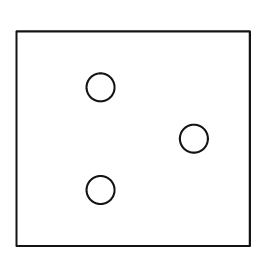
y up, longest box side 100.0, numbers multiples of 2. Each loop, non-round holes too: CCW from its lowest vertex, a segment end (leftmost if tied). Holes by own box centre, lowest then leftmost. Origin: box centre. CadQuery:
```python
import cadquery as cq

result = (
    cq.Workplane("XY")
    .moveTo(-50.0, -46.0)
    .lineTo(50.0, -46.0)
    .lineTo(50.0, 46.0)
    .lineTo(-50.0, 46.0)
    .close()
    .moveTo(-14.0, -22.0)
    .circle(6.0)
    .moveTo(26.0, 0.0)
    .circle(6.0)
    .moveTo(-14.0, 22.0)
    .circle(6.0)
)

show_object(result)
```